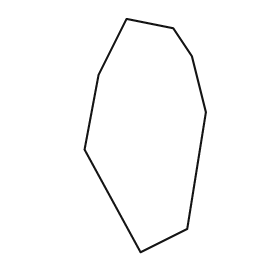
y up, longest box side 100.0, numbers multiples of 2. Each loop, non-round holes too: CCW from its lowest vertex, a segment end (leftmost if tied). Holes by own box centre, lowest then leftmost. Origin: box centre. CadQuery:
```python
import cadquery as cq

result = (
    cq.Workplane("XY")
    .moveTo(-2.0, -50.0)
    .lineTo(18.0, -40.0)
    .lineTo(26.0, 10.0)
    .lineTo(20.0, 34.0)
    .lineTo(12.0, 46.0)
    .lineTo(-8.0, 50.0)
    .lineTo(-20.0, 26.0)
    .lineTo(-26.0, -6.0)
    .close()
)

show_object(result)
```